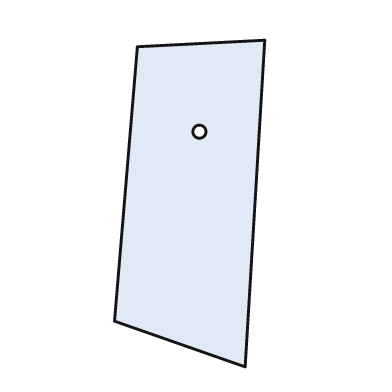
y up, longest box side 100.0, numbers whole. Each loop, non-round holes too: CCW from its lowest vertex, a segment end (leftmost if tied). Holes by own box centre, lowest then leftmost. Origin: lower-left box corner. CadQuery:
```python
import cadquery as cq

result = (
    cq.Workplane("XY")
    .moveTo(40.0, 0.0)
    .lineTo(46.0, 100.0)
    .lineTo(7.0, 98.0)
    .lineTo(0.0, 14.0)
    .close()
    .moveTo(26.0, 72.0)
    .circle(2.0)
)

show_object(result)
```